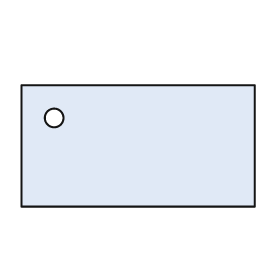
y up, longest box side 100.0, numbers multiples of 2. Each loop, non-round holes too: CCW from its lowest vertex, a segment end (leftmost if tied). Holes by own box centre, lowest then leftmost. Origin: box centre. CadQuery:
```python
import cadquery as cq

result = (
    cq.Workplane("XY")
    .moveTo(-50.0, -26.0)
    .lineTo(50.0, -26.0)
    .lineTo(50.0, 26.0)
    .lineTo(-50.0, 26.0)
    .close()
    .moveTo(-36.0, 12.0)
    .circle(4.0)
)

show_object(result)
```